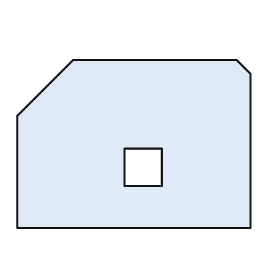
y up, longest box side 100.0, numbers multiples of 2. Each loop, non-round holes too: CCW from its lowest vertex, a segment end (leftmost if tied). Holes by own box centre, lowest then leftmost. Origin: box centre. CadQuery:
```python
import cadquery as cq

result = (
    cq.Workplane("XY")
    .moveTo(-50.0, -36.0)
    .lineTo(50.0, -36.0)
    .lineTo(50.0, 30.0)
    .lineTo(44.0, 36.0)
    .lineTo(-26.0, 36.0)
    .lineTo(-50.0, 12.0)
    .close()
    .moveTo(-4.0, -18.0)
    .lineTo(12.0, -18.0)
    .lineTo(12.0, -2.0)
    .lineTo(-4.0, -2.0)
    .close()
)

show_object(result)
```